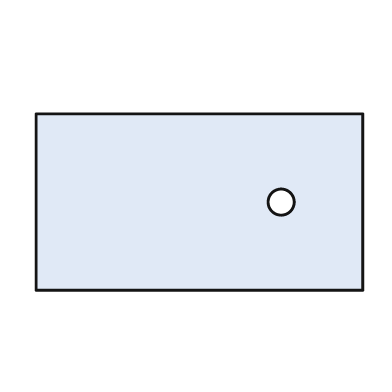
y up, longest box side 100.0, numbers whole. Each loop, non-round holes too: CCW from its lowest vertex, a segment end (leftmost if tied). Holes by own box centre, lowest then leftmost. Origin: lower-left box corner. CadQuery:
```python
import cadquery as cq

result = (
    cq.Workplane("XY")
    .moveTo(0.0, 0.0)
    .lineTo(100.0, 0.0)
    .lineTo(100.0, 54.0)
    .lineTo(0.0, 54.0)
    .close()
    .moveTo(75.0, 27.0)
    .circle(4.0)
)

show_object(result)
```